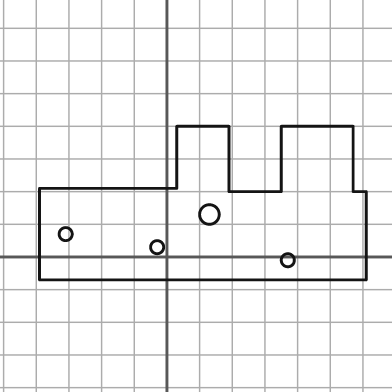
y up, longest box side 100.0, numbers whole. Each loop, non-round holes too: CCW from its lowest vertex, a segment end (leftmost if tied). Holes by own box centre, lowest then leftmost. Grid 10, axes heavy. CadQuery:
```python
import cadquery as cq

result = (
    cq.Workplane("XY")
    .moveTo(-39.0, -7.0)
    .lineTo(61.0, -7.0)
    .lineTo(61.0, 20.0)
    .lineTo(57.0, 20.0)
    .lineTo(57.0, 40.0)
    .lineTo(35.0, 40.0)
    .lineTo(35.0, 20.0)
    .lineTo(19.0, 20.0)
    .lineTo(19.0, 40.0)
    .lineTo(3.0, 40.0)
    .lineTo(3.0, 21.0)
    .lineTo(-39.0, 21.0)
    .close()
    .moveTo(37.0, -1.0)
    .circle(2.0)
    .moveTo(-3.0, 3.0)
    .circle(2.0)
    .moveTo(-31.0, 7.0)
    .circle(2.0)
    .moveTo(13.0, 13.0)
    .circle(3.0)
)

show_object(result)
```